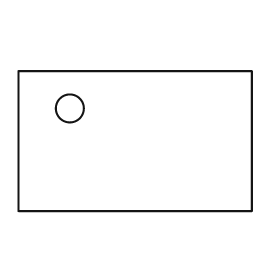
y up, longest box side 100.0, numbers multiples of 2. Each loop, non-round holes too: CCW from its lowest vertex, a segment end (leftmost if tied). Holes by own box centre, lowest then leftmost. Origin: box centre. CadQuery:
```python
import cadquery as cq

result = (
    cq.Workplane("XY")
    .moveTo(-50.0, -30.0)
    .lineTo(50.0, -30.0)
    .lineTo(50.0, 30.0)
    .lineTo(-50.0, 30.0)
    .close()
    .moveTo(-28.0, 14.0)
    .circle(6.0)
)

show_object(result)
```